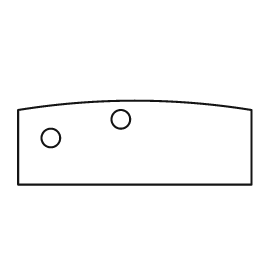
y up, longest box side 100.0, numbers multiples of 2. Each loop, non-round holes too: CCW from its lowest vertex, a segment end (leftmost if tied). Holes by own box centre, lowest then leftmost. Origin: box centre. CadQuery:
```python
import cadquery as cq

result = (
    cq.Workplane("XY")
    .moveTo(-50.0, -18.0)
    .lineTo(50.0, -18.0)
    .lineTo(50.0, 14.0)
    .threePointArc((0.0, 18.0), (-50.0, 14.0))
    .close()
    .moveTo(-36.0, 2.0)
    .circle(4.0)
    .moveTo(-6.0, 10.0)
    .circle(4.0)
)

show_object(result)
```